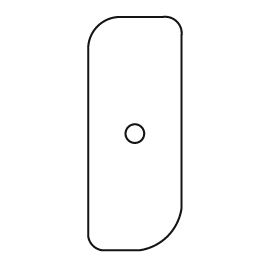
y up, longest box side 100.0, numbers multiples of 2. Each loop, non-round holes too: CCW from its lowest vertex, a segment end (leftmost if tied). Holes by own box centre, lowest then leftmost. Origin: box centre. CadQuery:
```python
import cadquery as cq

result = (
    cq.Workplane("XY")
    .moveTo(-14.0, -50.0)
    .lineTo(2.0, -50.0)
    .threePointArc((14.0, -44.0), (20.0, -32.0))
    .lineTo(20.0, 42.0)
    .threePointArc((18.0, 48.0), (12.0, 50.0))
    .lineTo(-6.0, 50.0)
    .threePointArc((-16.0, 46.0), (-20.0, 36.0))
    .lineTo(-20.0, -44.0)
    .threePointArc((-18.0, -48.0), (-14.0, -50.0))
    .close()
    .moveTo(0.0, 0.0)
    .circle(4.0)
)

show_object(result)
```